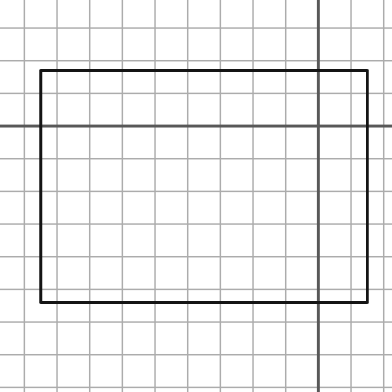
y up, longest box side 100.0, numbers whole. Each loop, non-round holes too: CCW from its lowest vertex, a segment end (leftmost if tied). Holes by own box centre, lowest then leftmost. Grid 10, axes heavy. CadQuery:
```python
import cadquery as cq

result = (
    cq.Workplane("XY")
    .moveTo(-85.0, -54.0)
    .lineTo(15.0, -54.0)
    .lineTo(15.0, 17.0)
    .lineTo(-85.0, 17.0)
    .close()
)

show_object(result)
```